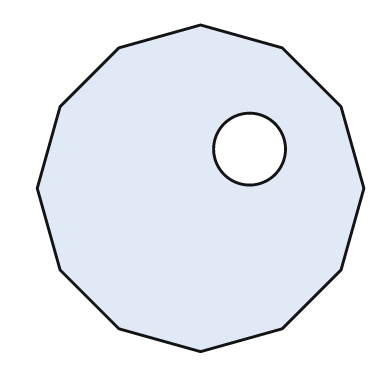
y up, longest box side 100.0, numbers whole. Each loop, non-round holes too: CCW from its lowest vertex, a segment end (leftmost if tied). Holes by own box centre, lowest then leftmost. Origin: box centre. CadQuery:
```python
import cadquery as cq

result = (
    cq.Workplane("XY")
    .moveTo(0.0, -50.0)
    .lineTo(25.0, -43.0)
    .lineTo(43.0, -25.0)
    .lineTo(50.0, 0.0)
    .lineTo(43.0, 25.0)
    .lineTo(25.0, 43.0)
    .lineTo(0.0, 50.0)
    .lineTo(-25.0, 43.0)
    .lineTo(-43.0, 25.0)
    .lineTo(-50.0, 0.0)
    .lineTo(-43.0, -25.0)
    .lineTo(-25.0, -43.0)
    .close()
    .moveTo(15.0, 12.0)
    .circle(11.0)
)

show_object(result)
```